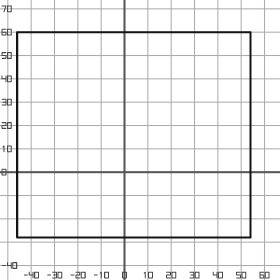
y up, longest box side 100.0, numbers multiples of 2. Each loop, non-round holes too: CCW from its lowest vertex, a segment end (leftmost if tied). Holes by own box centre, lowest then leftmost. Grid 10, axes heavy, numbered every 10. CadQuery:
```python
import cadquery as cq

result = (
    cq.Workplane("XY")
    .moveTo(-46.0, -28.0)
    .lineTo(54.0, -28.0)
    .lineTo(54.0, 60.0)
    .lineTo(-46.0, 60.0)
    .close()
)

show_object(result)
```